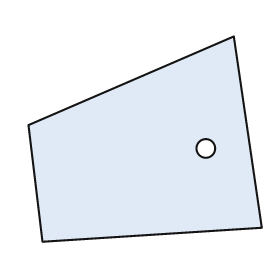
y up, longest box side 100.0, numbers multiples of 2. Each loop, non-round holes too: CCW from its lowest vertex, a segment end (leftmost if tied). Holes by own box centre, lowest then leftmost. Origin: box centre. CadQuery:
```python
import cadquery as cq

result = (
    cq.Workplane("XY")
    .moveTo(-44.0, -44.0)
    .lineTo(50.0, -38.0)
    .lineTo(38.0, 44.0)
    .lineTo(-50.0, 6.0)
    .close()
    .moveTo(26.0, -4.0)
    .circle(4.0)
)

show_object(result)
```